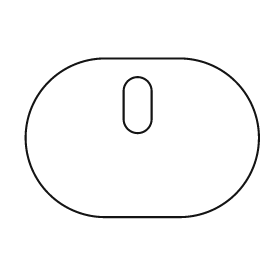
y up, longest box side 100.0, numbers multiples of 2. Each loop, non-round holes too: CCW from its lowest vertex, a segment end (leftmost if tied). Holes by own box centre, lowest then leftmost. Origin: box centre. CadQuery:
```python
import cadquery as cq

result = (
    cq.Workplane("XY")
    .moveTo(-16.0, -34.0)
    .lineTo(16.0, -34.0)
    .threePointArc((50.0, 0.0), (16.0, 34.0))
    .lineTo(-16.0, 34.0)
    .threePointArc((-50.0, 0.0), (-16.0, -34.0))
    .close()
    .moveTo(-8.0, 8.0)
    .threePointArc((-2.0, 2.0), (4.0, 8.0))
    .lineTo(4.0, 20.0)
    .threePointArc((-2.0, 26.0), (-8.0, 20.0))
    .close()
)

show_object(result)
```